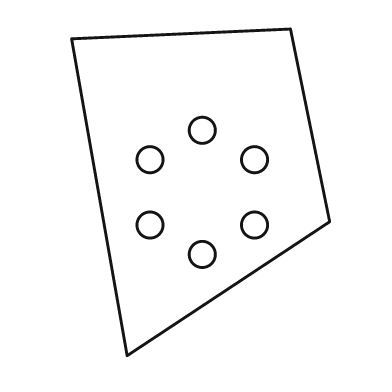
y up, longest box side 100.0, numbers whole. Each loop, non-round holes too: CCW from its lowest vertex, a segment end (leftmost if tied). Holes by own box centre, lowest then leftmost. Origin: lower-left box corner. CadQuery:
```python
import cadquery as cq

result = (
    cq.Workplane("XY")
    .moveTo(17.0, 0.0)
    .lineTo(79.0, 41.0)
    .lineTo(67.0, 100.0)
    .lineTo(0.0, 97.0)
    .close()
    .moveTo(40.0, 31.0)
    .circle(4.0)
    .moveTo(24.0, 40.0)
    .circle(4.0)
    .moveTo(56.0, 40.0)
    .circle(4.0)
    .moveTo(24.0, 60.0)
    .circle(4.0)
    .moveTo(56.0, 60.0)
    .circle(4.0)
    .moveTo(40.0, 69.0)
    .circle(4.0)
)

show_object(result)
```